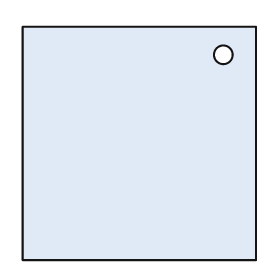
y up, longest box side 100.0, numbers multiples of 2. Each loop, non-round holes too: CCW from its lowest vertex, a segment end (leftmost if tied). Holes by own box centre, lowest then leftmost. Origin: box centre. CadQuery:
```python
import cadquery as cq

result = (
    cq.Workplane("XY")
    .moveTo(-50.0, -50.0)
    .lineTo(50.0, -50.0)
    .lineTo(50.0, 50.0)
    .lineTo(-50.0, 50.0)
    .close()
    .moveTo(36.0, 38.0)
    .circle(4.0)
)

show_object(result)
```